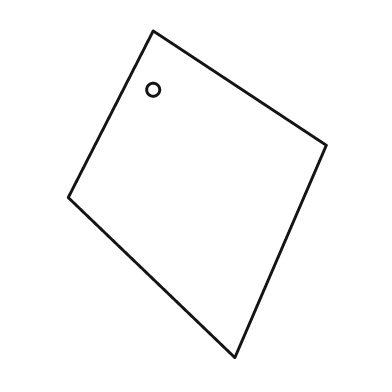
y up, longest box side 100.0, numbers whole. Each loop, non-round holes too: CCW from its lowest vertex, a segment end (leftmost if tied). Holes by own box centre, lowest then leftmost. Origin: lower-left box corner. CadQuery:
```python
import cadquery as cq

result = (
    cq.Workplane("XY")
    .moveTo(51.0, 0.0)
    .lineTo(79.0, 65.0)
    .lineTo(26.0, 100.0)
    .lineTo(0.0, 49.0)
    .close()
    .moveTo(26.0, 82.0)
    .circle(2.0)
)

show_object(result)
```